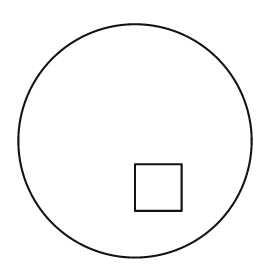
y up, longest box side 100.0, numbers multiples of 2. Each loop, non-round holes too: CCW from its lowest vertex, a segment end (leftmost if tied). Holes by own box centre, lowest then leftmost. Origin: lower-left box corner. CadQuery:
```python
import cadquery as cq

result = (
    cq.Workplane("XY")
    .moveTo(50.0, 50.0)
    .circle(50.0)
    .moveTo(50.0, 20.0)
    .lineTo(70.0, 20.0)
    .lineTo(70.0, 40.0)
    .lineTo(50.0, 40.0)
    .close()
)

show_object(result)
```